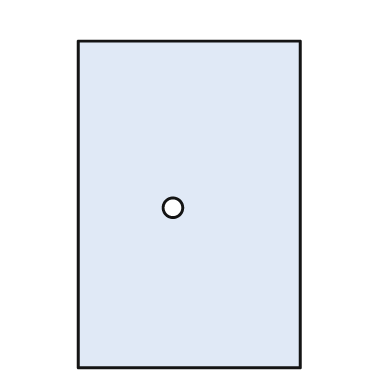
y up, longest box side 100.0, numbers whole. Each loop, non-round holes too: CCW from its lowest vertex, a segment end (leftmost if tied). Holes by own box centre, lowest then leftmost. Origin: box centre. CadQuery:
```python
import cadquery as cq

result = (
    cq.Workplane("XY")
    .moveTo(-34.0, -50.0)
    .lineTo(34.0, -50.0)
    .lineTo(34.0, 50.0)
    .lineTo(-34.0, 50.0)
    .close()
    .moveTo(-5.0, -1.0)
    .circle(3.0)
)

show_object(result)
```